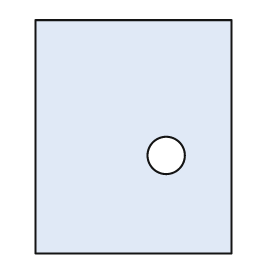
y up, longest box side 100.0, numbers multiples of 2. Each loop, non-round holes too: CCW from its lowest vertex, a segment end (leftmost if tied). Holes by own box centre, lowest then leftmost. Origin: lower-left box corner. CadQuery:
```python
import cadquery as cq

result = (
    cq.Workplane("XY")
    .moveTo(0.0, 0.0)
    .lineTo(84.0, 0.0)
    .lineTo(84.0, 100.0)
    .lineTo(0.0, 100.0)
    .close()
    .moveTo(56.0, 42.0)
    .circle(8.0)
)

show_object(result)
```